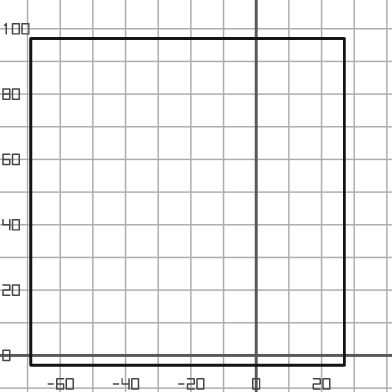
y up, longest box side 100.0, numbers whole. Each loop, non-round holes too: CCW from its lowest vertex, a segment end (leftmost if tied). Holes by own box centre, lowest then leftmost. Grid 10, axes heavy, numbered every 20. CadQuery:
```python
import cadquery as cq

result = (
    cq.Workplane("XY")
    .moveTo(-69.0, -3.0)
    .lineTo(27.0, -3.0)
    .lineTo(27.0, 97.0)
    .lineTo(-69.0, 97.0)
    .close()
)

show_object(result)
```